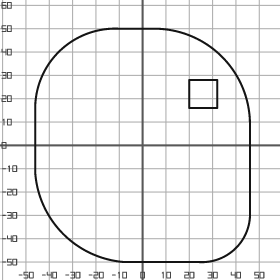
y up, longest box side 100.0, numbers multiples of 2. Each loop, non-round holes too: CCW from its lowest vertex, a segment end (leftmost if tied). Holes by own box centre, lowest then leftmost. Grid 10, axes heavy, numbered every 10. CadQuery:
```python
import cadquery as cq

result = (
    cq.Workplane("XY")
    .moveTo(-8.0, -50.0)
    .lineTo(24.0, -50.0)
    .threePointArc((40.0, -44.0), (46.0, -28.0))
    .lineTo(46.0, 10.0)
    .threePointArc((34.0, 38.0), (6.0, 50.0))
    .lineTo(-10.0, 50.0)
    .threePointArc((-36.0, 40.0), (-46.0, 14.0))
    .lineTo(-46.0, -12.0)
    .threePointArc((-34.0, -38.0), (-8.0, -50.0))
    .close()
    .moveTo(20.0, 16.0)
    .lineTo(32.0, 16.0)
    .lineTo(32.0, 28.0)
    .lineTo(20.0, 28.0)
    .close()
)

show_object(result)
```